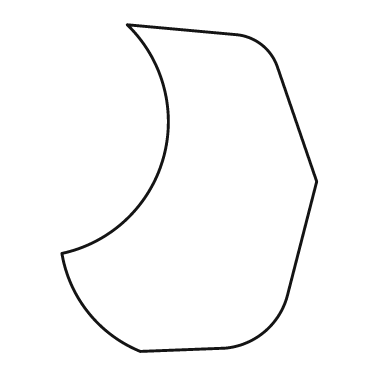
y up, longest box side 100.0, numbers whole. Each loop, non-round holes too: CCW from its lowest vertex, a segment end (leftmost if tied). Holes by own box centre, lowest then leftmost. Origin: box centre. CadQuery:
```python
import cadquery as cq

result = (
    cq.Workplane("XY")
    .moveTo(-15.0, -50.0)
    .lineTo(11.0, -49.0)
    .threePointArc((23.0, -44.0), (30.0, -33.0))
    .lineTo(39.0, 2.0)
    .lineTo(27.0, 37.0)
    .threePointArc((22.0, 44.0), (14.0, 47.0))
    .lineTo(-19.0, 50.0)
    .threePointArc((-8.0, 9.0), (-39.0, -20.0))
    .threePointArc((-31.0, -38.0), (-15.0, -50.0))
    .close()
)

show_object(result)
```